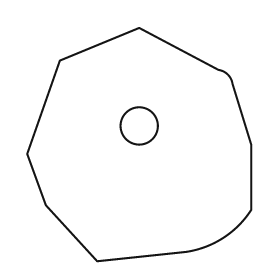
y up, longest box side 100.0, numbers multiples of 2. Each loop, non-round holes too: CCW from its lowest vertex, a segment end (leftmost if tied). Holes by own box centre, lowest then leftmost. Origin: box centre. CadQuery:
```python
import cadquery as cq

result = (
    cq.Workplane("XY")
    .moveTo(-18.0, -50.0)
    .lineTo(20.0, -46.0)
    .threePointArc((36.0, -40.0), (48.0, -28.0))
    .lineTo(48.0, 0.0)
    .lineTo(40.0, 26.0)
    .threePointArc((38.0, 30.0), (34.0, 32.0))
    .lineTo(0.0, 50.0)
    .lineTo(-34.0, 36.0)
    .lineTo(-48.0, -4.0)
    .lineTo(-40.0, -26.0)
    .close()
    .moveTo(0.0, 8.0)
    .circle(8.0)
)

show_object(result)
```